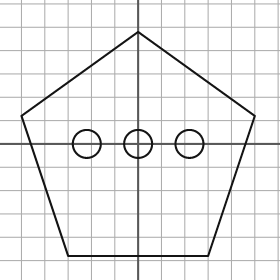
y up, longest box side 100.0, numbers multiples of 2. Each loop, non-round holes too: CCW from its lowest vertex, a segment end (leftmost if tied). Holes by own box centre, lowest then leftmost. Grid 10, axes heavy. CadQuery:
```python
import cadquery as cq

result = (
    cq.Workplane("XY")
    .moveTo(-30.0, -48.0)
    .lineTo(30.0, -48.0)
    .lineTo(50.0, 12.0)
    .lineTo(0.0, 48.0)
    .lineTo(-50.0, 12.0)
    .close()
    .moveTo(-22.0, 0.0)
    .circle(6.0)
    .moveTo(0.0, 0.0)
    .circle(6.0)
    .moveTo(22.0, 0.0)
    .circle(6.0)
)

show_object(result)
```